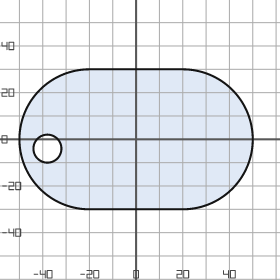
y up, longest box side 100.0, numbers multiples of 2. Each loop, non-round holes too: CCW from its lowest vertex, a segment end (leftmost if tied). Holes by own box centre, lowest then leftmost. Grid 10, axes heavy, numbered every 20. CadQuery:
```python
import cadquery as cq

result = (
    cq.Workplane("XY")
    .moveTo(-20.0, -30.0)
    .lineTo(20.0, -30.0)
    .threePointArc((50.0, 0.0), (20.0, 30.0))
    .lineTo(-20.0, 30.0)
    .threePointArc((-50.0, 0.0), (-20.0, -30.0))
    .close()
    .moveTo(-38.0, -4.0)
    .circle(6.0)
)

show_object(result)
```